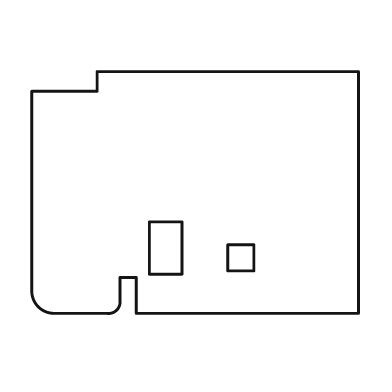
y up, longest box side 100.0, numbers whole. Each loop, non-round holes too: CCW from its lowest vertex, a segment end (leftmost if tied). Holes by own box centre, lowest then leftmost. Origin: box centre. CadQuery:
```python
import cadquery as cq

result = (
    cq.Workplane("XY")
    .moveTo(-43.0, -37.0)
    .lineTo(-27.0, -37.0)
    .threePointArc((-24.0, -36.0), (-23.0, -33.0))
    .lineTo(-23.0, -26.0)
    .lineTo(-18.0, -26.0)
    .lineTo(-18.0, -37.0)
    .lineTo(50.0, -37.0)
    .lineTo(50.0, 37.0)
    .lineTo(-30.0, 37.0)
    .lineTo(-30.0, 31.0)
    .lineTo(-50.0, 31.0)
    .lineTo(-50.0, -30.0)
    .threePointArc((-48.0, -35.0), (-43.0, -37.0))
    .close()
    .moveTo(10.0, -24.0)
    .lineTo(18.0, -24.0)
    .lineTo(18.0, -16.0)
    .lineTo(10.0, -16.0)
    .close()
    .moveTo(-14.0, -25.0)
    .lineTo(-4.0, -25.0)
    .lineTo(-4.0, -9.0)
    .lineTo(-14.0, -9.0)
    .close()
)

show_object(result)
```